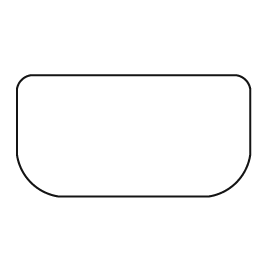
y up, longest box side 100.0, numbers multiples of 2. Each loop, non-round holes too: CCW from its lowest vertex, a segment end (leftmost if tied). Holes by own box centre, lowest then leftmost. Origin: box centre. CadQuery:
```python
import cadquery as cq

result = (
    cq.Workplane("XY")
    .moveTo(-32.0, -26.0)
    .lineTo(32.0, -26.0)
    .threePointArc((44.0, -20.0), (50.0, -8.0))
    .lineTo(50.0, 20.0)
    .threePointArc((48.0, 24.0), (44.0, 26.0))
    .lineTo(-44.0, 26.0)
    .threePointArc((-48.0, 24.0), (-50.0, 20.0))
    .lineTo(-50.0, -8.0)
    .threePointArc((-44.0, -20.0), (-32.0, -26.0))
    .close()
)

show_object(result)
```